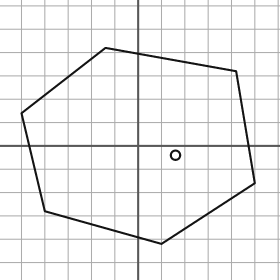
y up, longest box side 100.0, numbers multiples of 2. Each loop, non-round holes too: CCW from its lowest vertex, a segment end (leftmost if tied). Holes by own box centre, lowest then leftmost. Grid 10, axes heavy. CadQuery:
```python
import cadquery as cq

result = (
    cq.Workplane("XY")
    .moveTo(10.0, -42.0)
    .lineTo(50.0, -16.0)
    .lineTo(42.0, 32.0)
    .lineTo(-14.0, 42.0)
    .lineTo(-50.0, 14.0)
    .lineTo(-40.0, -28.0)
    .close()
    .moveTo(16.0, -4.0)
    .circle(2.0)
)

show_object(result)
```